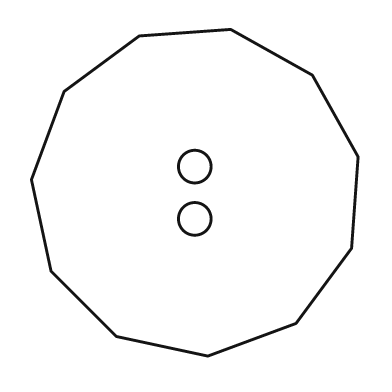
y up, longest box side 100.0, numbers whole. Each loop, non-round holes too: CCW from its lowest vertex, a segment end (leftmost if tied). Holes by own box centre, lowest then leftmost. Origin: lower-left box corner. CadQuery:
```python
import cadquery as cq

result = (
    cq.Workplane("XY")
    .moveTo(54.0, 0.0)
    .lineTo(81.0, 10.0)
    .lineTo(98.0, 33.0)
    .lineTo(100.0, 61.0)
    .lineTo(86.0, 86.0)
    .lineTo(61.0, 100.0)
    .lineTo(33.0, 98.0)
    .lineTo(10.0, 81.0)
    .lineTo(0.0, 54.0)
    .lineTo(6.0, 26.0)
    .lineTo(26.0, 6.0)
    .close()
    .moveTo(50.0, 42.0)
    .circle(5.0)
    .moveTo(50.0, 58.0)
    .circle(5.0)
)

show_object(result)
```